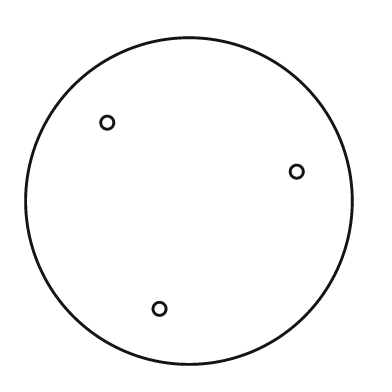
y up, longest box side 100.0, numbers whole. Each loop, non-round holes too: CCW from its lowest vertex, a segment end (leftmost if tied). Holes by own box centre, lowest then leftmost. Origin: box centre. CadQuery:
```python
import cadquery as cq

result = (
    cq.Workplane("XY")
    .moveTo(0.0, 0.0)
    .circle(50.0)
    .moveTo(-9.0, -33.0)
    .circle(2.0)
    .moveTo(33.0, 9.0)
    .circle(2.0)
    .moveTo(-25.0, 24.0)
    .circle(2.0)
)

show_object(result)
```